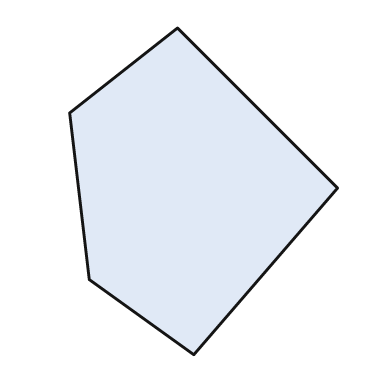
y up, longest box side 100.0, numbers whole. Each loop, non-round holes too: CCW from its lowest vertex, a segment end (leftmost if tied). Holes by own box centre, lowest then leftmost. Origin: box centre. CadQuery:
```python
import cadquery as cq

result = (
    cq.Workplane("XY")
    .moveTo(-3.0, -50.0)
    .lineTo(41.0, 1.0)
    .lineTo(-8.0, 50.0)
    .lineTo(-41.0, 24.0)
    .lineTo(-35.0, -27.0)
    .close()
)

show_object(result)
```